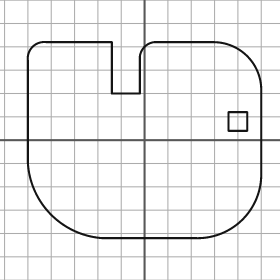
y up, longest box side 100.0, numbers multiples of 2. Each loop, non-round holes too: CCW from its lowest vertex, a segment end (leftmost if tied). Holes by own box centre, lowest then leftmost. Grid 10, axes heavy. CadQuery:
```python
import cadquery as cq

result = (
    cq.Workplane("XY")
    .moveTo(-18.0, -42.0)
    .lineTo(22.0, -42.0)
    .threePointArc((42.0, -34.0), (50.0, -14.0))
    .lineTo(50.0, 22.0)
    .threePointArc((44.0, 36.0), (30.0, 42.0))
    .lineTo(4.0, 42.0)
    .threePointArc((0.0, 40.0), (-2.0, 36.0))
    .lineTo(-2.0, 20.0)
    .lineTo(-14.0, 20.0)
    .lineTo(-14.0, 42.0)
    .lineTo(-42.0, 42.0)
    .threePointArc((-48.0, 40.0), (-50.0, 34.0))
    .lineTo(-50.0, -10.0)
    .threePointArc((-40.0, -32.0), (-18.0, -42.0))
    .close()
    .moveTo(36.0, 4.0)
    .lineTo(44.0, 4.0)
    .lineTo(44.0, 12.0)
    .lineTo(36.0, 12.0)
    .close()
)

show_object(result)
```